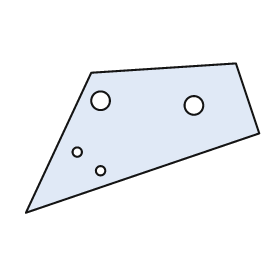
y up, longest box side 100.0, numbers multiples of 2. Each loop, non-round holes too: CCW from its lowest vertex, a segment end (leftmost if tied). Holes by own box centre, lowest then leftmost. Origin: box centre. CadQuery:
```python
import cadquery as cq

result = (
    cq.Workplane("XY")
    .moveTo(-50.0, -32.0)
    .lineTo(50.0, 2.0)
    .lineTo(40.0, 32.0)
    .lineTo(-22.0, 28.0)
    .close()
    .moveTo(-18.0, -14.0)
    .circle(2.0)
    .moveTo(-28.0, -6.0)
    .circle(2.0)
    .moveTo(22.0, 14.0)
    .circle(4.0)
    .moveTo(-18.0, 16.0)
    .circle(4.0)
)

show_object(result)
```